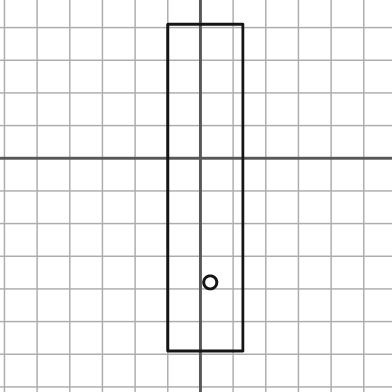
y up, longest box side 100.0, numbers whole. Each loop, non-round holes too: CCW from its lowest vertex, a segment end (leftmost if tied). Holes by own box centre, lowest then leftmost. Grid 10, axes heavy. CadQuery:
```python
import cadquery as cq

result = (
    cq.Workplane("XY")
    .moveTo(-10.0, -59.0)
    .lineTo(13.0, -59.0)
    .lineTo(13.0, 41.0)
    .lineTo(-10.0, 41.0)
    .close()
    .moveTo(3.0, -38.0)
    .circle(2.0)
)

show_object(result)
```